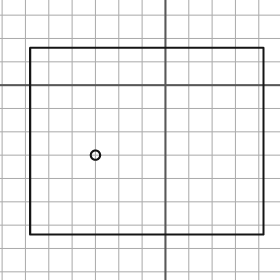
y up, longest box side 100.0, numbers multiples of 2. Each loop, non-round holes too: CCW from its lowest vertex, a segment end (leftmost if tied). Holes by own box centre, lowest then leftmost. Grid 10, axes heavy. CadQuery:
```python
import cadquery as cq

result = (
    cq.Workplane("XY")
    .moveTo(-58.0, -64.0)
    .lineTo(42.0, -64.0)
    .lineTo(42.0, 16.0)
    .lineTo(-58.0, 16.0)
    .close()
    .moveTo(-30.0, -30.0)
    .circle(2.0)
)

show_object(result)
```